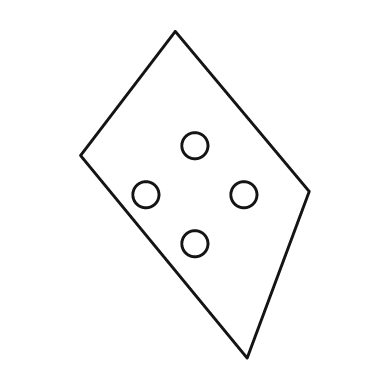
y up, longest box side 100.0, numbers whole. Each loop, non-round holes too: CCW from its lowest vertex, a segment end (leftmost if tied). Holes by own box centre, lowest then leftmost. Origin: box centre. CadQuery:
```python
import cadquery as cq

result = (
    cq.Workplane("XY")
    .moveTo(16.0, -50.0)
    .lineTo(35.0, 1.0)
    .lineTo(-6.0, 50.0)
    .lineTo(-35.0, 12.0)
    .close()
    .moveTo(0.0, -15.0)
    .circle(4.0)
    .moveTo(-15.0, 0.0)
    .circle(4.0)
    .moveTo(15.0, 0.0)
    .circle(4.0)
    .moveTo(0.0, 15.0)
    .circle(4.0)
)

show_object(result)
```